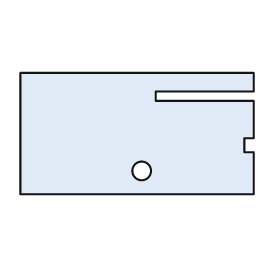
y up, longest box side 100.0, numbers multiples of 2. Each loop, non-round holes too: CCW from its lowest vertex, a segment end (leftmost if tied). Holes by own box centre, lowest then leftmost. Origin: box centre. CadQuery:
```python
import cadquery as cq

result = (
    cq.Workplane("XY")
    .moveTo(-50.0, -26.0)
    .lineTo(50.0, -26.0)
    .lineTo(50.0, -8.0)
    .lineTo(46.0, -8.0)
    .lineTo(46.0, -2.0)
    .lineTo(50.0, -2.0)
    .lineTo(50.0, 14.0)
    .lineTo(8.0, 14.0)
    .lineTo(8.0, 18.0)
    .lineTo(50.0, 18.0)
    .lineTo(50.0, 26.0)
    .lineTo(-50.0, 26.0)
    .close()
    .moveTo(2.0, -16.0)
    .circle(4.0)
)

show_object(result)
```